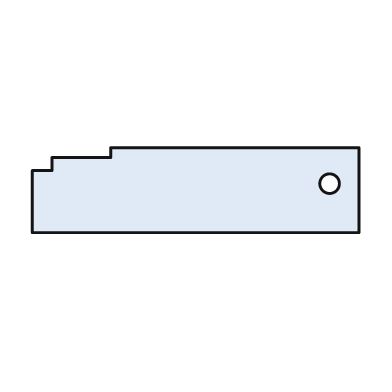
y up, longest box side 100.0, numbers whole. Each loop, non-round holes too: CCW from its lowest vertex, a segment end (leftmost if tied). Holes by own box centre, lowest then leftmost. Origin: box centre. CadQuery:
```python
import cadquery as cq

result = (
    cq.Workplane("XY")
    .moveTo(-50.0, -13.0)
    .lineTo(50.0, -13.0)
    .lineTo(50.0, 13.0)
    .lineTo(-26.0, 13.0)
    .lineTo(-26.0, 10.0)
    .lineTo(-44.0, 10.0)
    .lineTo(-44.0, 6.0)
    .lineTo(-50.0, 6.0)
    .close()
    .moveTo(41.0, 2.0)
    .circle(3.0)
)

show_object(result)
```